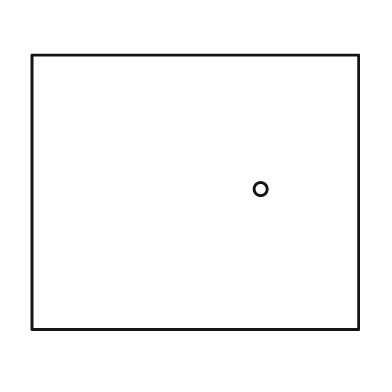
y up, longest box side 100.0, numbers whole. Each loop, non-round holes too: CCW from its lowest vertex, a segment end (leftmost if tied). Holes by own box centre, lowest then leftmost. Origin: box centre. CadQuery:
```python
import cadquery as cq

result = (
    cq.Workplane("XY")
    .moveTo(-50.0, -42.0)
    .lineTo(50.0, -42.0)
    .lineTo(50.0, 42.0)
    .lineTo(-50.0, 42.0)
    .close()
    .moveTo(20.0, 1.0)
    .circle(2.0)
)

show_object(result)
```